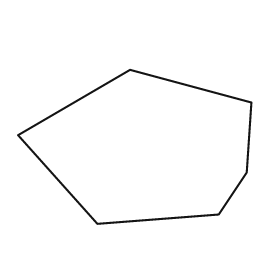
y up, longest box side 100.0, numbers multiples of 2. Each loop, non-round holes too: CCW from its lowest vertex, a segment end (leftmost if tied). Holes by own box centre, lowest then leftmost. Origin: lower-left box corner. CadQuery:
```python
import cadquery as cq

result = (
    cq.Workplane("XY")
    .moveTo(34.0, 0.0)
    .lineTo(86.0, 4.0)
    .lineTo(98.0, 22.0)
    .lineTo(100.0, 52.0)
    .lineTo(48.0, 66.0)
    .lineTo(0.0, 38.0)
    .close()
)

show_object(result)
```